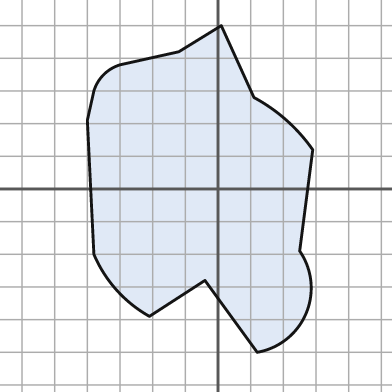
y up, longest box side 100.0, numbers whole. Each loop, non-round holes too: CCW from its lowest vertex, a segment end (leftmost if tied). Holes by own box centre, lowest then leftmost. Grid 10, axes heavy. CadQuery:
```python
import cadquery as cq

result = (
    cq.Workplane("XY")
    .moveTo(12.0, -50.0)
    .threePointArc((27.0, -38.0), (25.0, -19.0))
    .lineTo(29.0, 12.0)
    .threePointArc((21.0, 21.0), (11.0, 28.0))
    .lineTo(1.0, 50.0)
    .lineTo(-12.0, 42.0)
    .lineTo(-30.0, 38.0)
    .threePointArc((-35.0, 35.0), (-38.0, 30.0))
    .lineTo(-40.0, 21.0)
    .lineTo(-38.0, -20.0)
    .threePointArc((-31.0, -31.0), (-21.0, -39.0))
    .lineTo(-4.0, -28.0)
    .close()
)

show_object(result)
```